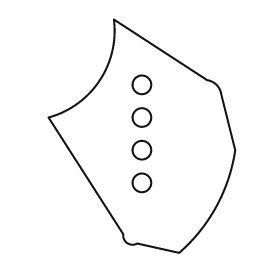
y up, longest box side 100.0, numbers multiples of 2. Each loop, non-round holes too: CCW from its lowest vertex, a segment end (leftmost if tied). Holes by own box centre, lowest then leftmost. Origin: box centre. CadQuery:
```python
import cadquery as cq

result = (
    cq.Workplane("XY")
    .moveTo(16.0, -50.0)
    .threePointArc((32.0, -30.0), (40.0, -6.0))
    .lineTo(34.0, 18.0)
    .threePointArc((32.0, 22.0), (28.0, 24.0))
    .lineTo(-12.0, 50.0)
    .threePointArc((-18.0, 24.0), (-40.0, 8.0))
    .lineTo(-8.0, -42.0)
    .threePointArc((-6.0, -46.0), (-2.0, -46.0))
    .close()
    .moveTo(0.0, -20.0)
    .circle(4.0)
    .moveTo(0.0, -6.0)
    .circle(4.0)
    .moveTo(0.0, 8.0)
    .circle(4.0)
    .moveTo(0.0, 22.0)
    .circle(4.0)
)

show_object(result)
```